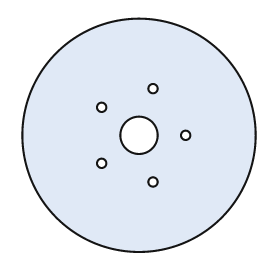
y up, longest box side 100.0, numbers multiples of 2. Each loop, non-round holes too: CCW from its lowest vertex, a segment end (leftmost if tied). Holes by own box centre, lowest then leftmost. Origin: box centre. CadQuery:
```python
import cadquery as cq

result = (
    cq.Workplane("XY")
    .moveTo(0.0, 0.0)
    .circle(50.0)
    .moveTo(6.0, -20.0)
    .circle(2.0)
    .moveTo(-16.0, -12.0)
    .circle(2.0)
    .moveTo(0.0, 0.0)
    .circle(8.0)
    .moveTo(20.0, 0.0)
    .circle(2.0)
    .moveTo(-16.0, 12.0)
    .circle(2.0)
    .moveTo(6.0, 20.0)
    .circle(2.0)
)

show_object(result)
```